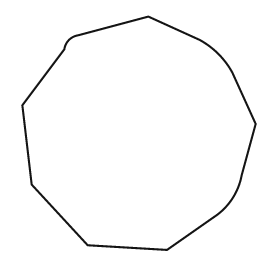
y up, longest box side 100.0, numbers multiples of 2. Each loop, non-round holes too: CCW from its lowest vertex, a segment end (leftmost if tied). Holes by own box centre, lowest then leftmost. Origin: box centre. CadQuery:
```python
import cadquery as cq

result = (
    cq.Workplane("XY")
    .moveTo(12.0, -50.0)
    .lineTo(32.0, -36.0)
    .threePointArc((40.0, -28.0), (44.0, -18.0))
    .lineTo(50.0, 4.0)
    .lineTo(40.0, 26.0)
    .threePointArc((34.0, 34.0), (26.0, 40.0))
    .lineTo(4.0, 50.0)
    .lineTo(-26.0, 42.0)
    .threePointArc((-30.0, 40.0), (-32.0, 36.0))
    .lineTo(-50.0, 12.0)
    .lineTo(-46.0, -22.0)
    .lineTo(-22.0, -48.0)
    .close()
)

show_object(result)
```